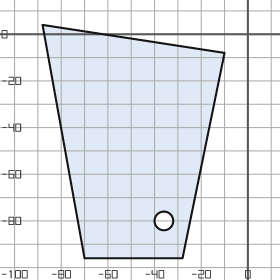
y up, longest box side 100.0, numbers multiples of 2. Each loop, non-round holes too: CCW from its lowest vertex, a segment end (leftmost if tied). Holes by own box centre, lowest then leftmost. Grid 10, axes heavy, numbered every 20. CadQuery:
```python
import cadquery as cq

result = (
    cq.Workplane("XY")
    .moveTo(-70.0, -96.0)
    .lineTo(-28.0, -96.0)
    .lineTo(-10.0, -8.0)
    .lineTo(-88.0, 4.0)
    .close()
    .moveTo(-36.0, -80.0)
    .circle(4.0)
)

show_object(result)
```